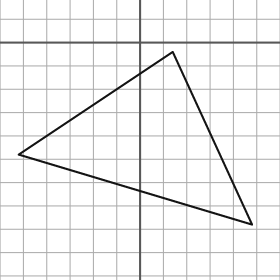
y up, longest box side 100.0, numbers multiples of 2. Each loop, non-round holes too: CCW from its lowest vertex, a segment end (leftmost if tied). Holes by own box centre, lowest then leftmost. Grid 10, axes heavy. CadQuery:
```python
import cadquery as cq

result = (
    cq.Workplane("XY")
    .moveTo(48.0, -78.0)
    .lineTo(14.0, -4.0)
    .lineTo(-52.0, -48.0)
    .close()
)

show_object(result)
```